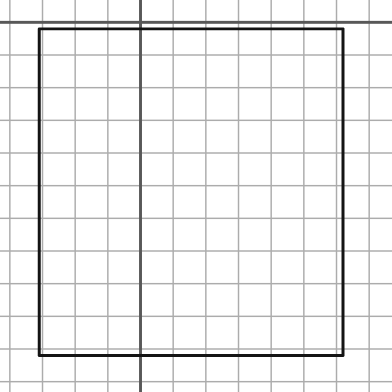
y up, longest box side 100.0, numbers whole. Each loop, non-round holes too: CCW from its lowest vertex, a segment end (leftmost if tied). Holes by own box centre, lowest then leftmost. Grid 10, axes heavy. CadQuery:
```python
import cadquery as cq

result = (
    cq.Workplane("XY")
    .moveTo(-31.0, -102.0)
    .lineTo(62.0, -102.0)
    .lineTo(62.0, -2.0)
    .lineTo(-31.0, -2.0)
    .close()
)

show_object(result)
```